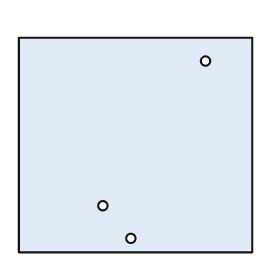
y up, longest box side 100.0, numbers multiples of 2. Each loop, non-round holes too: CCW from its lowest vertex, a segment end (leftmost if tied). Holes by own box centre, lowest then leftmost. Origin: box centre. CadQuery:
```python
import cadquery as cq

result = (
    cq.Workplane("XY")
    .moveTo(-50.0, -46.0)
    .lineTo(50.0, -46.0)
    .lineTo(50.0, 46.0)
    .lineTo(-50.0, 46.0)
    .close()
    .moveTo(-2.0, -40.0)
    .circle(2.0)
    .moveTo(-14.0, -26.0)
    .circle(2.0)
    .moveTo(30.0, 36.0)
    .circle(2.0)
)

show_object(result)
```